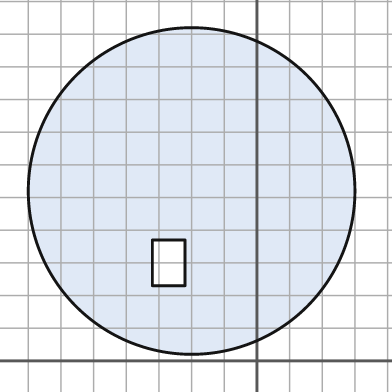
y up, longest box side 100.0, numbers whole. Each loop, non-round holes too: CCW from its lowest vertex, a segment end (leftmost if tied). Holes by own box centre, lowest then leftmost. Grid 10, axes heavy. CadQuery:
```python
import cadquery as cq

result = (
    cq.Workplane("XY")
    .moveTo(-20.0, 52.0)
    .circle(50.0)
    .moveTo(-32.0, 23.0)
    .lineTo(-22.0, 23.0)
    .lineTo(-22.0, 37.0)
    .lineTo(-32.0, 37.0)
    .close()
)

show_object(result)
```